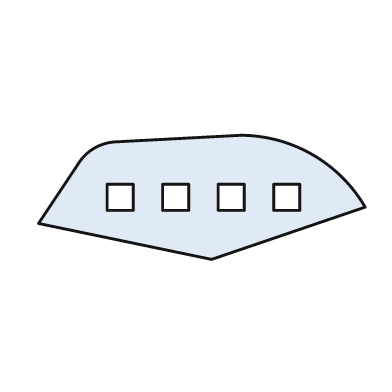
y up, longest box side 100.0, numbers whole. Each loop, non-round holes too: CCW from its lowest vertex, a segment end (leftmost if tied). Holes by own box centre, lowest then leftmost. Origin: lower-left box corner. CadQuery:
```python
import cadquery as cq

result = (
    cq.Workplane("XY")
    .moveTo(53.0, 0.0)
    .lineTo(100.0, 16.0)
    .threePointArc((84.0, 32.0), (62.0, 38.0))
    .lineTo(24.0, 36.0)
    .threePointArc((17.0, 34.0), (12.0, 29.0))
    .lineTo(0.0, 11.0)
    .close()
    .moveTo(21.0, 15.0)
    .lineTo(29.0, 15.0)
    .lineTo(29.0, 23.0)
    .lineTo(21.0, 23.0)
    .close()
    .moveTo(38.0, 15.0)
    .lineTo(46.0, 15.0)
    .lineTo(46.0, 23.0)
    .lineTo(38.0, 23.0)
    .close()
    .moveTo(55.0, 15.0)
    .lineTo(63.0, 15.0)
    .lineTo(63.0, 23.0)
    .lineTo(55.0, 23.0)
    .close()
    .moveTo(72.0, 15.0)
    .lineTo(80.0, 15.0)
    .lineTo(80.0, 23.0)
    .lineTo(72.0, 23.0)
    .close()
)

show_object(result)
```